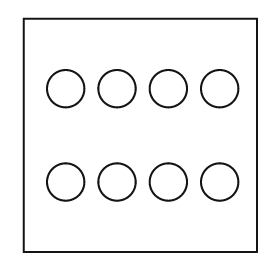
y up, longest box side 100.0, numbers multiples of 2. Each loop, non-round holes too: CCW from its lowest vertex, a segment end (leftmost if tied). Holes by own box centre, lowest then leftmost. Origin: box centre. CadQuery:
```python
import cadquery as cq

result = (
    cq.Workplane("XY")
    .moveTo(-50.0, -50.0)
    .lineTo(50.0, -50.0)
    .lineTo(50.0, 50.0)
    .lineTo(-50.0, 50.0)
    .close()
    .moveTo(-32.0, -20.0)
    .circle(8.0)
    .moveTo(-10.0, -20.0)
    .circle(8.0)
    .moveTo(12.0, -20.0)
    .circle(8.0)
    .moveTo(34.0, -20.0)
    .circle(8.0)
    .moveTo(-32.0, 20.0)
    .circle(8.0)
    .moveTo(-10.0, 20.0)
    .circle(8.0)
    .moveTo(12.0, 20.0)
    .circle(8.0)
    .moveTo(34.0, 20.0)
    .circle(8.0)
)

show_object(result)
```